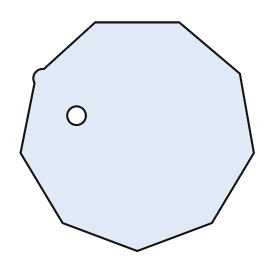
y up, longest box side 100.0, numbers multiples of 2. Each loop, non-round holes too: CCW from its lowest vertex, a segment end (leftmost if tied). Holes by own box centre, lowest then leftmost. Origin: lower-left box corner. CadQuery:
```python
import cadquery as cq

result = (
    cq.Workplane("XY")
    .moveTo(50.0, 0.0)
    .lineTo(82.0, 12.0)
    .lineTo(100.0, 42.0)
    .lineTo(94.0, 76.0)
    .lineTo(68.0, 98.0)
    .lineTo(32.0, 98.0)
    .lineTo(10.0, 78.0)
    .threePointArc((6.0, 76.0), (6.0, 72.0))
    .lineTo(0.0, 42.0)
    .lineTo(18.0, 12.0)
    .close()
    .moveTo(24.0, 58.0)
    .circle(4.0)
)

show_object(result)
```